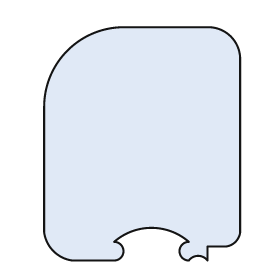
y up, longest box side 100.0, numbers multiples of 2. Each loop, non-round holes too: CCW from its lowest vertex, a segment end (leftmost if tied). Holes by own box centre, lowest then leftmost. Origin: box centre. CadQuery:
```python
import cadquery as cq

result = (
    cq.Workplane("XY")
    .moveTo(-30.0, -50.0)
    .lineTo(-12.0, -50.0)
    .threePointArc((-8.0, -46.0), (-12.0, -42.0))
    .threePointArc((4.0, -36.0), (20.0, -42.0))
    .threePointArc((16.0, -46.0), (20.0, -50.0))
    .threePointArc((24.0, -48.0), (28.0, -50.0))
    .lineTo(28.0, -44.0)
    .lineTo(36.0, -44.0)
    .threePointArc((40.0, -42.0), (42.0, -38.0))
    .lineTo(42.0, 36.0)
    .threePointArc((38.0, 46.0), (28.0, 50.0))
    .lineTo(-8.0, 50.0)
    .threePointArc((-32.0, 40.0), (-42.0, 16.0))
    .lineTo(-42.0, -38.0)
    .threePointArc((-38.0, -46.0), (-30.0, -50.0))
    .close()
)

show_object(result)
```